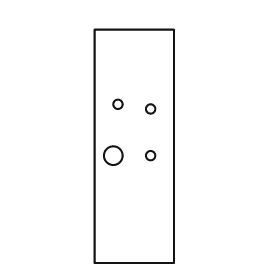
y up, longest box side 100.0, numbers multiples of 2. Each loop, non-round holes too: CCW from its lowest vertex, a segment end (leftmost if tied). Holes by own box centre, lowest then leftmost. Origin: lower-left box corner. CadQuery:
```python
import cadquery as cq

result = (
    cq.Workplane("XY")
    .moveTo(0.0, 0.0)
    .lineTo(34.0, 0.0)
    .lineTo(34.0, 100.0)
    .lineTo(0.0, 100.0)
    .close()
    .moveTo(8.0, 46.0)
    .circle(4.0)
    .moveTo(24.0, 46.0)
    .circle(2.0)
    .moveTo(24.0, 66.0)
    .circle(2.0)
    .moveTo(10.0, 68.0)
    .circle(2.0)
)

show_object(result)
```